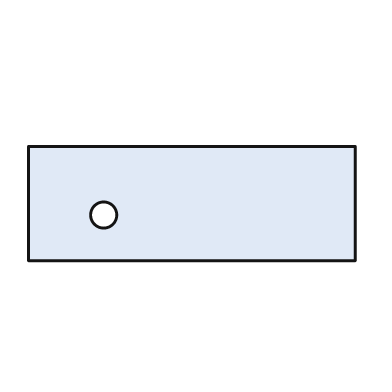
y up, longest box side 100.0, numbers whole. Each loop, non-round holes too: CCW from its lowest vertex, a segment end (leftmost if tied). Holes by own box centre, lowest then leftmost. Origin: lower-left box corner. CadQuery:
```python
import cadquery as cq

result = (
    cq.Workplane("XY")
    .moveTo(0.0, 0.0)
    .lineTo(100.0, 0.0)
    .lineTo(100.0, 35.0)
    .lineTo(0.0, 35.0)
    .close()
    .moveTo(23.0, 14.0)
    .circle(4.0)
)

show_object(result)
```